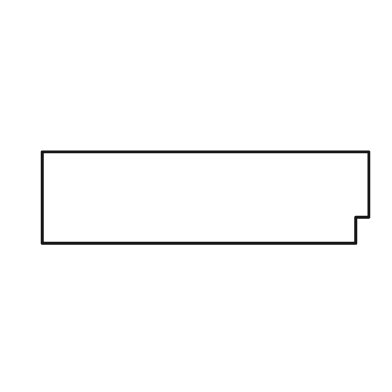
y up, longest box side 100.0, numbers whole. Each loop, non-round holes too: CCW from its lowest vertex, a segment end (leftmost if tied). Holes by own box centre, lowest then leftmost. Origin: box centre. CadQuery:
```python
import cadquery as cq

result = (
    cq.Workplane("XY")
    .moveTo(-50.0, -14.0)
    .lineTo(46.0, -14.0)
    .lineTo(46.0, -6.0)
    .lineTo(50.0, -6.0)
    .lineTo(50.0, 14.0)
    .lineTo(-50.0, 14.0)
    .close()
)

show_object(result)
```